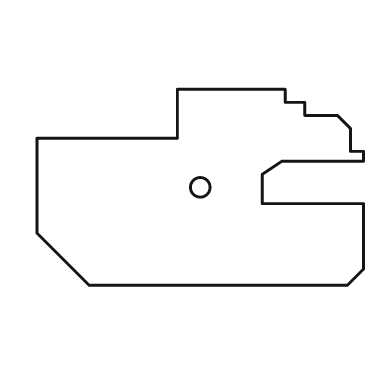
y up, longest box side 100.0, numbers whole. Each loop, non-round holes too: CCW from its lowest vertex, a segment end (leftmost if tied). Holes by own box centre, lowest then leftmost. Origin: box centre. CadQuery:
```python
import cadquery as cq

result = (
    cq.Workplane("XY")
    .moveTo(-34.0, -30.0)
    .lineTo(45.0, -30.0)
    .lineTo(50.0, -25.0)
    .lineTo(50.0, -5.0)
    .lineTo(19.0, -5.0)
    .lineTo(19.0, 4.0)
    .lineTo(25.0, 8.0)
    .lineTo(50.0, 8.0)
    .lineTo(50.0, 11.0)
    .lineTo(46.0, 11.0)
    .lineTo(46.0, 18.0)
    .lineTo(42.0, 22.0)
    .lineTo(32.0, 22.0)
    .lineTo(32.0, 26.0)
    .lineTo(26.0, 26.0)
    .lineTo(26.0, 30.0)
    .lineTo(-7.0, 30.0)
    .lineTo(-7.0, 15.0)
    .lineTo(-50.0, 15.0)
    .lineTo(-50.0, -14.0)
    .close()
    .moveTo(0.0, 0.0)
    .circle(3.0)
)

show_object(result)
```